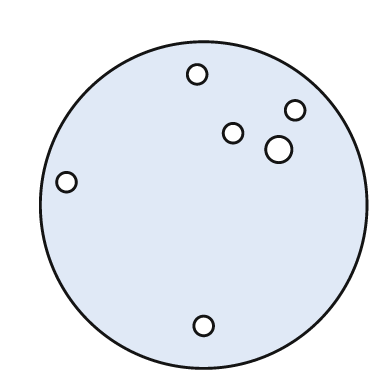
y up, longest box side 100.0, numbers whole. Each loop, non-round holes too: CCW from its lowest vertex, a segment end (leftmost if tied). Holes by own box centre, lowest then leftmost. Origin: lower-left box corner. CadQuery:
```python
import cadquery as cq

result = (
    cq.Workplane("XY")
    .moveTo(50.0, 50.0)
    .circle(50.0)
    .moveTo(50.0, 13.0)
    .circle(3.0)
    .moveTo(8.0, 57.0)
    .circle(3.0)
    .moveTo(73.0, 67.0)
    .circle(4.0)
    .moveTo(59.0, 72.0)
    .circle(3.0)
    .moveTo(78.0, 79.0)
    .circle(3.0)
    .moveTo(48.0, 90.0)
    .circle(3.0)
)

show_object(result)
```